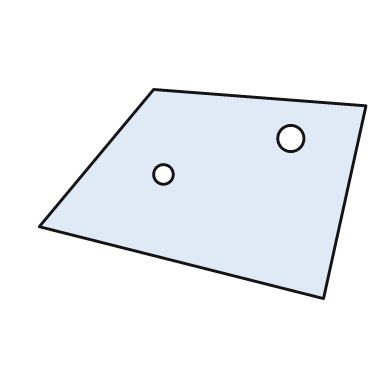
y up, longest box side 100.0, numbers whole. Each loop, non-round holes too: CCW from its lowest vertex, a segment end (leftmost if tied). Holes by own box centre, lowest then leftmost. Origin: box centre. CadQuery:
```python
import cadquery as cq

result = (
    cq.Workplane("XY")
    .moveTo(37.0, -32.0)
    .lineTo(50.0, 27.0)
    .lineTo(-15.0, 32.0)
    .lineTo(-50.0, -10.0)
    .close()
    .moveTo(-12.0, 6.0)
    .circle(3.0)
    .moveTo(27.0, 17.0)
    .circle(4.0)
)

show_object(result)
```